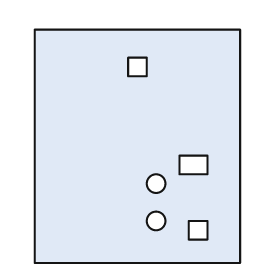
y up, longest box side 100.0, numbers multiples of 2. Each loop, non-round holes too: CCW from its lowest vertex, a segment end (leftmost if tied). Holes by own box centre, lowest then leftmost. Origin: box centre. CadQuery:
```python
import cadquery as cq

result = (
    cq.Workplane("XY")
    .moveTo(-44.0, -50.0)
    .lineTo(44.0, -50.0)
    .lineTo(44.0, 50.0)
    .lineTo(-44.0, 50.0)
    .close()
    .moveTo(22.0, -40.0)
    .lineTo(30.0, -40.0)
    .lineTo(30.0, -32.0)
    .lineTo(22.0, -32.0)
    .close()
    .moveTo(8.0, -32.0)
    .circle(4.0)
    .moveTo(8.0, -16.0)
    .circle(4.0)
    .moveTo(18.0, -12.0)
    .lineTo(30.0, -12.0)
    .lineTo(30.0, -4.0)
    .lineTo(18.0, -4.0)
    .close()
    .moveTo(-4.0, 30.0)
    .lineTo(4.0, 30.0)
    .lineTo(4.0, 38.0)
    .lineTo(-4.0, 38.0)
    .close()
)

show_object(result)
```